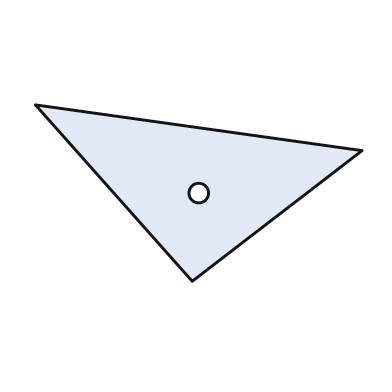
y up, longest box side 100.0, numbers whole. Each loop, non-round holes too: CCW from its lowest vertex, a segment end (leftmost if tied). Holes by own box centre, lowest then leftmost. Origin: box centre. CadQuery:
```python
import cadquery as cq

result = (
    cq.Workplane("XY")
    .moveTo(-2.0, -27.0)
    .lineTo(50.0, 13.0)
    .lineTo(-50.0, 27.0)
    .close()
    .moveTo(0.0, 0.0)
    .circle(3.0)
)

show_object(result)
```